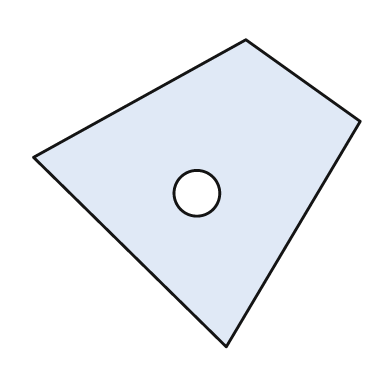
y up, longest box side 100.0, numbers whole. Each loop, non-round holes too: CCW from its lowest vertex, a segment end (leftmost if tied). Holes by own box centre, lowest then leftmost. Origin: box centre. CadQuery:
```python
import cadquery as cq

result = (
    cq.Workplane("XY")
    .moveTo(9.0, -47.0)
    .lineTo(50.0, 22.0)
    .lineTo(15.0, 47.0)
    .lineTo(-50.0, 11.0)
    .close()
    .moveTo(0.0, 0.0)
    .circle(7.0)
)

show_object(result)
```